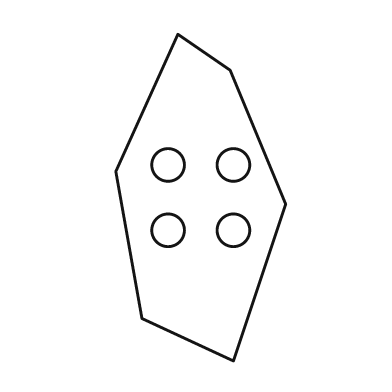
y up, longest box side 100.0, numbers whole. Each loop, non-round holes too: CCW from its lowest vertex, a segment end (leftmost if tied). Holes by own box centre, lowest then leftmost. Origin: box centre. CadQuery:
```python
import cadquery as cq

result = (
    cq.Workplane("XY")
    .moveTo(10.0, -50.0)
    .lineTo(26.0, -2.0)
    .lineTo(9.0, 39.0)
    .lineTo(-7.0, 50.0)
    .lineTo(-26.0, 8.0)
    .lineTo(-18.0, -37.0)
    .close()
    .moveTo(-10.0, -10.0)
    .circle(5.0)
    .moveTo(10.0, -10.0)
    .circle(5.0)
    .moveTo(-10.0, 10.0)
    .circle(5.0)
    .moveTo(10.0, 10.0)
    .circle(5.0)
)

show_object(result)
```